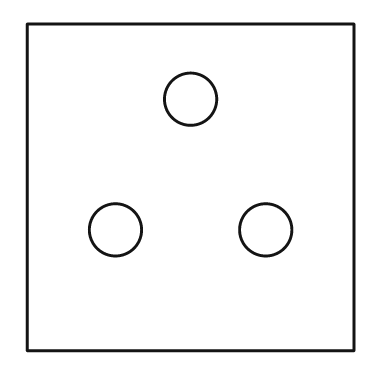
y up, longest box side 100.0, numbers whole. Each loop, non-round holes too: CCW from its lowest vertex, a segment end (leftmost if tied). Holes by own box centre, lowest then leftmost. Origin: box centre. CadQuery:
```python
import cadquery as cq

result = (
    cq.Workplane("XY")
    .moveTo(-50.0, -50.0)
    .lineTo(50.0, -50.0)
    .lineTo(50.0, 50.0)
    .lineTo(-50.0, 50.0)
    .close()
    .moveTo(-23.0, -13.0)
    .circle(8.0)
    .moveTo(23.0, -13.0)
    .circle(8.0)
    .moveTo(0.0, 27.0)
    .circle(8.0)
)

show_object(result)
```